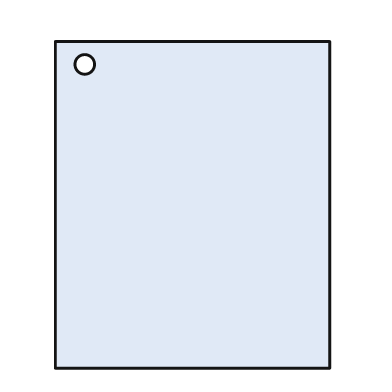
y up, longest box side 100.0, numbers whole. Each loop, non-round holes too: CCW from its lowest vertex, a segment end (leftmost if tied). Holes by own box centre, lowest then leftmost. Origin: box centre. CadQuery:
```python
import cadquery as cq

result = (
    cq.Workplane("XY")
    .moveTo(-42.0, -50.0)
    .lineTo(42.0, -50.0)
    .lineTo(42.0, 50.0)
    .lineTo(-42.0, 50.0)
    .close()
    .moveTo(-33.0, 43.0)
    .circle(3.0)
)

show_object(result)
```